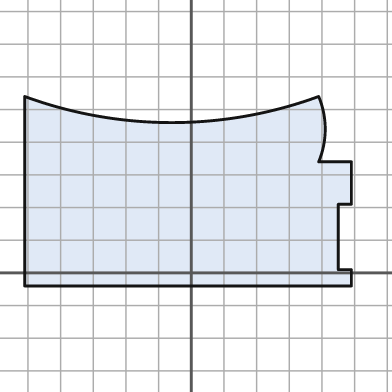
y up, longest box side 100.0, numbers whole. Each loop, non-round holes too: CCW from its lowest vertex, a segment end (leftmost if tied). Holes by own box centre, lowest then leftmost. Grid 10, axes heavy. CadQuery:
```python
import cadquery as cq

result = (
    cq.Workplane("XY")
    .moveTo(-51.0, -4.0)
    .lineTo(49.0, -4.0)
    .lineTo(49.0, 1.0)
    .lineTo(45.0, 1.0)
    .lineTo(45.0, 21.0)
    .lineTo(49.0, 21.0)
    .lineTo(49.0, 34.0)
    .lineTo(39.0, 34.0)
    .threePointArc((41.0, 44.0), (39.0, 54.0))
    .threePointArc((-6.0, 46.0), (-51.0, 54.0))
    .close()
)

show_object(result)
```